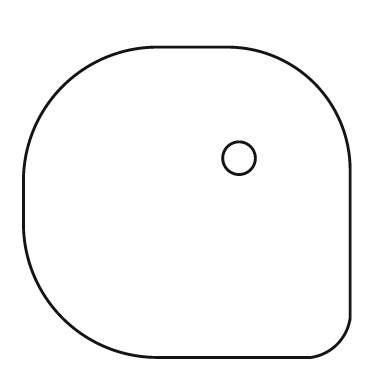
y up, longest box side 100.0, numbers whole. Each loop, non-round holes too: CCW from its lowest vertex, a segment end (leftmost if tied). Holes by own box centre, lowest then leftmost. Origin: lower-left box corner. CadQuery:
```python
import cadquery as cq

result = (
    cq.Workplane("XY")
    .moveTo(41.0, 0.0)
    .lineTo(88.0, 0.0)
    .threePointArc((96.0, 4.0), (100.0, 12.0))
    .lineTo(100.0, 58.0)
    .threePointArc((89.0, 84.0), (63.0, 95.0))
    .lineTo(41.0, 95.0)
    .threePointArc((12.0, 83.0), (0.0, 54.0))
    .lineTo(0.0, 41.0)
    .threePointArc((12.0, 12.0), (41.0, 0.0))
    .close()
    .moveTo(66.0, 61.0)
    .circle(5.0)
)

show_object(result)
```